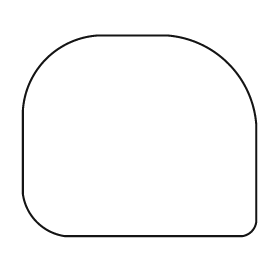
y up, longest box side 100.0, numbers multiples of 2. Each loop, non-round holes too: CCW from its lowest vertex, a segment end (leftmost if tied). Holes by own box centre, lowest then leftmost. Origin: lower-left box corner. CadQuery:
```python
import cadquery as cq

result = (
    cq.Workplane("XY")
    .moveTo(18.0, 0.0)
    .lineTo(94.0, 0.0)
    .threePointArc((98.0, 2.0), (100.0, 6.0))
    .lineTo(100.0, 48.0)
    .threePointArc((88.0, 74.0), (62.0, 86.0))
    .lineTo(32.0, 86.0)
    .threePointArc((10.0, 76.0), (0.0, 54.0))
    .lineTo(0.0, 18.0)
    .threePointArc((6.0, 6.0), (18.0, 0.0))
    .close()
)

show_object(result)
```